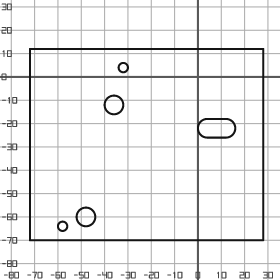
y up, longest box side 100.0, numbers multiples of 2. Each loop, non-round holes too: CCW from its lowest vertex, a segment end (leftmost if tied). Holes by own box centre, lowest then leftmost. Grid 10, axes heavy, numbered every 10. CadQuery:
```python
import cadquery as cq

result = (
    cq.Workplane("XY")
    .moveTo(-72.0, -70.0)
    .lineTo(28.0, -70.0)
    .lineTo(28.0, 12.0)
    .lineTo(-72.0, 12.0)
    .close()
    .moveTo(-58.0, -64.0)
    .circle(2.0)
    .moveTo(-48.0, -60.0)
    .circle(4.0)
    .moveTo(4.0, -26.0)
    .lineTo(12.0, -26.0)
    .threePointArc((16.0, -22.0), (12.0, -18.0))
    .lineTo(4.0, -18.0)
    .threePointArc((0.0, -22.0), (4.0, -26.0))
    .close()
    .moveTo(-36.0, -12.0)
    .circle(4.0)
    .moveTo(-32.0, 4.0)
    .circle(2.0)
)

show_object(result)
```